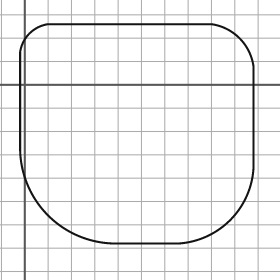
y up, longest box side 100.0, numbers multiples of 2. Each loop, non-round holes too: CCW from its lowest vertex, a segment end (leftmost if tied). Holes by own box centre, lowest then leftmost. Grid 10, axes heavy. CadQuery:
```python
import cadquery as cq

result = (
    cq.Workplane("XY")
    .moveTo(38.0, -68.0)
    .lineTo(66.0, -68.0)
    .threePointArc((88.0, -58.0), (98.0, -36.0))
    .lineTo(98.0, 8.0)
    .threePointArc((92.0, 20.0), (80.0, 26.0))
    .lineTo(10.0, 26.0)
    .threePointArc((2.0, 22.0), (-2.0, 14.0))
    .lineTo(-2.0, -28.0)
    .threePointArc((10.0, -56.0), (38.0, -68.0))
    .close()
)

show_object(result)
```